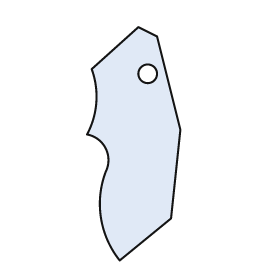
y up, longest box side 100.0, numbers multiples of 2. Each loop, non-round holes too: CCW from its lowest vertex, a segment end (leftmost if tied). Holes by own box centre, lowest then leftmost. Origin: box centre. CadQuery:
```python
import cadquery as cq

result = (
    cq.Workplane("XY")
    .moveTo(-6.0, -50.0)
    .lineTo(16.0, -32.0)
    .lineTo(20.0, 6.0)
    .lineTo(10.0, 46.0)
    .lineTo(2.0, 50.0)
    .lineTo(-18.0, 32.0)
    .threePointArc((-16.0, 18.0), (-20.0, 4.0))
    .threePointArc((-12.0, -2.0), (-12.0, -12.0))
    .threePointArc((-14.0, -32.0), (-6.0, -50.0))
    .close()
    .moveTo(6.0, 30.0)
    .circle(4.0)
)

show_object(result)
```